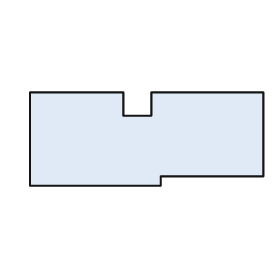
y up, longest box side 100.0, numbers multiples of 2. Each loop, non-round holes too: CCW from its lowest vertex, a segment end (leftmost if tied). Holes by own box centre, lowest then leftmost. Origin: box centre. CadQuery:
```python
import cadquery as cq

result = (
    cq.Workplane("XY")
    .moveTo(-50.0, -20.0)
    .lineTo(6.0, -20.0)
    .lineTo(6.0, -16.0)
    .lineTo(50.0, -16.0)
    .lineTo(50.0, 20.0)
    .lineTo(2.0, 20.0)
    .lineTo(2.0, 10.0)
    .lineTo(-10.0, 10.0)
    .lineTo(-10.0, 20.0)
    .lineTo(-50.0, 20.0)
    .close()
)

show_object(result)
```